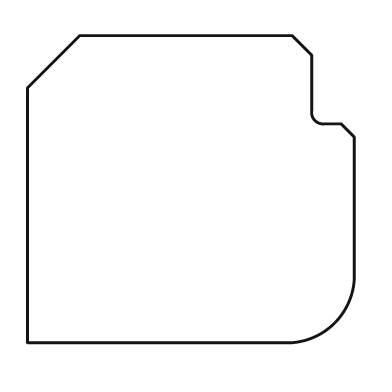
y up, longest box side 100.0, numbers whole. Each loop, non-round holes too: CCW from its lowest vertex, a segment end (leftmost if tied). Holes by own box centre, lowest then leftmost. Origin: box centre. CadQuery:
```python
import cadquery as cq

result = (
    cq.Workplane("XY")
    .moveTo(-50.0, -47.0)
    .lineTo(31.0, -47.0)
    .threePointArc((44.0, -41.0), (50.0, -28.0))
    .lineTo(50.0, 16.0)
    .lineTo(46.0, 20.0)
    .lineTo(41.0, 20.0)
    .threePointArc((38.0, 21.0), (37.0, 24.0))
    .lineTo(37.0, 41.0)
    .lineTo(31.0, 47.0)
    .lineTo(-34.0, 47.0)
    .lineTo(-50.0, 31.0)
    .close()
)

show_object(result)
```